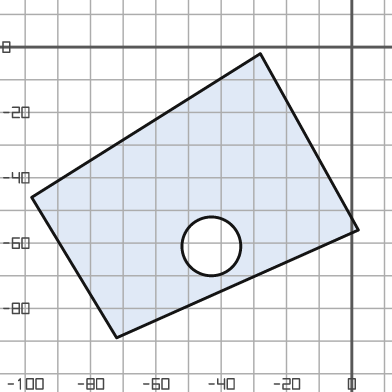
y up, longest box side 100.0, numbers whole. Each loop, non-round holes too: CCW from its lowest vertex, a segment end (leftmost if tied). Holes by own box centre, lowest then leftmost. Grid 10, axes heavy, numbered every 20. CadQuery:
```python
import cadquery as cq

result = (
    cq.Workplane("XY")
    .moveTo(-72.0, -89.0)
    .lineTo(2.0, -56.0)
    .lineTo(-28.0, -2.0)
    .lineTo(-98.0, -46.0)
    .close()
    .moveTo(-43.0, -61.0)
    .circle(9.0)
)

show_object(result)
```